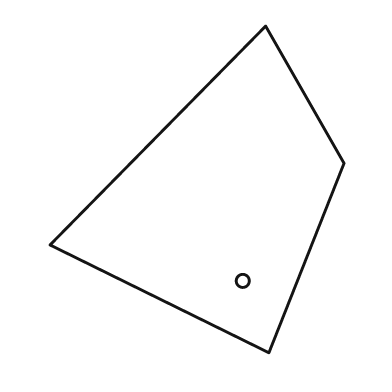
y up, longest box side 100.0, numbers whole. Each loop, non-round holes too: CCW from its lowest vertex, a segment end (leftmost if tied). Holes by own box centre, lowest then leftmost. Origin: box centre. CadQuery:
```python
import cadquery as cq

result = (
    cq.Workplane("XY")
    .moveTo(22.0, -50.0)
    .lineTo(45.0, 8.0)
    .lineTo(21.0, 50.0)
    .lineTo(-45.0, -17.0)
    .close()
    .moveTo(14.0, -28.0)
    .circle(2.0)
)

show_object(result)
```